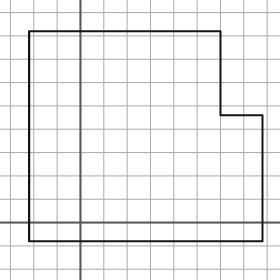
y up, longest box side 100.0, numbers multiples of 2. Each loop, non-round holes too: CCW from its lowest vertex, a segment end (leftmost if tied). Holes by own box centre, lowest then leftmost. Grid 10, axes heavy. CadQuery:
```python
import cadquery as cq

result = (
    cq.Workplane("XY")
    .moveTo(-22.0, -8.0)
    .lineTo(78.0, -8.0)
    .lineTo(78.0, 46.0)
    .lineTo(60.0, 46.0)
    .lineTo(60.0, 82.0)
    .lineTo(-22.0, 82.0)
    .close()
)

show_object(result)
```